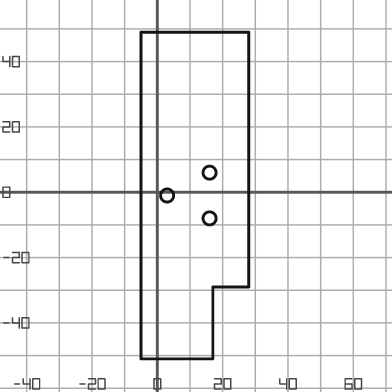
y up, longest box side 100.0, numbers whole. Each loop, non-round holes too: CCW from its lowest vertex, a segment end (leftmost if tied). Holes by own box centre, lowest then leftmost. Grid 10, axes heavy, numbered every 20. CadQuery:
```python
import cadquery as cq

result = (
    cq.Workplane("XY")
    .moveTo(-5.0, -51.0)
    .lineTo(17.0, -51.0)
    .lineTo(17.0, -29.0)
    .lineTo(28.0, -29.0)
    .lineTo(28.0, 49.0)
    .lineTo(-5.0, 49.0)
    .close()
    .moveTo(16.0, -8.0)
    .circle(2.0)
    .moveTo(3.0, -1.0)
    .circle(2.0)
    .moveTo(16.0, 6.0)
    .circle(2.0)
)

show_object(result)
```